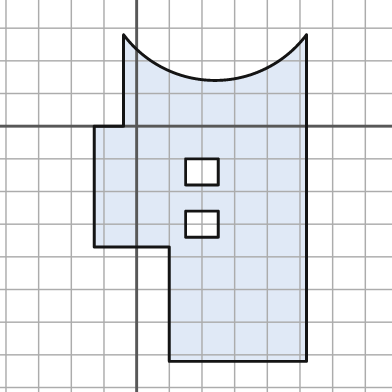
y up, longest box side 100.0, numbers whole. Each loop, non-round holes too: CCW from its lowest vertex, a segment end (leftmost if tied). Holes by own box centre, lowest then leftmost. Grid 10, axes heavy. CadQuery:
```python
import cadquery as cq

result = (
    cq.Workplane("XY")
    .moveTo(10.0, -72.0)
    .lineTo(52.0, -72.0)
    .lineTo(52.0, 28.0)
    .threePointArc((24.0, 14.0), (-4.0, 28.0))
    .lineTo(-4.0, 0.0)
    .lineTo(-13.0, 0.0)
    .lineTo(-13.0, -37.0)
    .lineTo(10.0, -37.0)
    .close()
    .moveTo(15.0, -34.0)
    .lineTo(25.0, -34.0)
    .lineTo(25.0, -26.0)
    .lineTo(15.0, -26.0)
    .close()
    .moveTo(15.0, -18.0)
    .lineTo(25.0, -18.0)
    .lineTo(25.0, -10.0)
    .lineTo(15.0, -10.0)
    .close()
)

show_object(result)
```